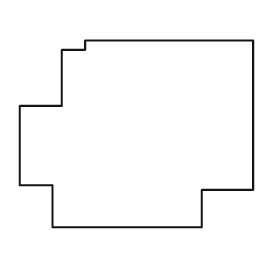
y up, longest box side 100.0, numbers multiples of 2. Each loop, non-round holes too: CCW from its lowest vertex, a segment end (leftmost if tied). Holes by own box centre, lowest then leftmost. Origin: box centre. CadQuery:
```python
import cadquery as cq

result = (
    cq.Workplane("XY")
    .moveTo(-36.0, -40.0)
    .lineTo(28.0, -40.0)
    .lineTo(28.0, -24.0)
    .lineTo(50.0, -24.0)
    .lineTo(50.0, 40.0)
    .lineTo(-22.0, 40.0)
    .lineTo(-22.0, 36.0)
    .lineTo(-32.0, 36.0)
    .lineTo(-32.0, 12.0)
    .lineTo(-50.0, 12.0)
    .lineTo(-50.0, -22.0)
    .lineTo(-36.0, -22.0)
    .close()
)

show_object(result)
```